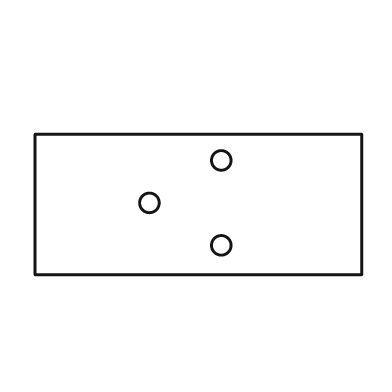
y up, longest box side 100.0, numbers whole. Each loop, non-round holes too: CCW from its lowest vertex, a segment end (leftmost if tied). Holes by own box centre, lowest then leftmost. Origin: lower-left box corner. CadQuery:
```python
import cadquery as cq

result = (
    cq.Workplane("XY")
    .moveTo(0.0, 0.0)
    .lineTo(100.0, 0.0)
    .lineTo(100.0, 43.0)
    .lineTo(0.0, 43.0)
    .close()
    .moveTo(57.0, 9.0)
    .circle(3.0)
    .moveTo(35.0, 22.0)
    .circle(3.0)
    .moveTo(57.0, 35.0)
    .circle(3.0)
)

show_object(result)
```